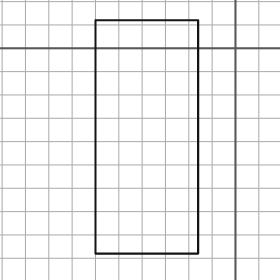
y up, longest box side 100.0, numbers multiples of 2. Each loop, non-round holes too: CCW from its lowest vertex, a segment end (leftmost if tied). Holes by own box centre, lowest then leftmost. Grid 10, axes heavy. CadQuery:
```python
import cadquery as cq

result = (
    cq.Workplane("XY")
    .moveTo(-60.0, -88.0)
    .lineTo(-16.0, -88.0)
    .lineTo(-16.0, 12.0)
    .lineTo(-60.0, 12.0)
    .close()
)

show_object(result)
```